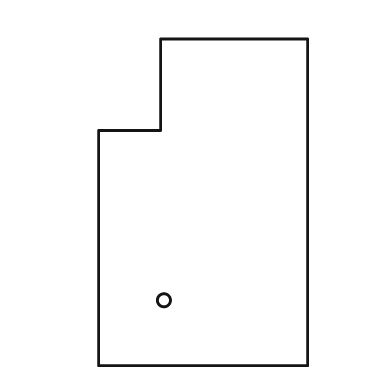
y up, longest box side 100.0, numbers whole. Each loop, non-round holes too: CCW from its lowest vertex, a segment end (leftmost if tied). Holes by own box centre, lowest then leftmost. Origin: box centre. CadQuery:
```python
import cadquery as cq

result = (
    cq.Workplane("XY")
    .moveTo(-32.0, -50.0)
    .lineTo(32.0, -50.0)
    .lineTo(32.0, 50.0)
    .lineTo(-13.0, 50.0)
    .lineTo(-13.0, 22.0)
    .lineTo(-32.0, 22.0)
    .close()
    .moveTo(-12.0, -30.0)
    .circle(2.0)
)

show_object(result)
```